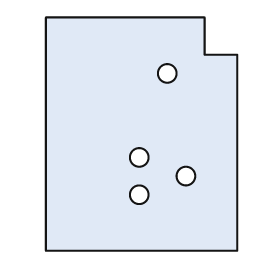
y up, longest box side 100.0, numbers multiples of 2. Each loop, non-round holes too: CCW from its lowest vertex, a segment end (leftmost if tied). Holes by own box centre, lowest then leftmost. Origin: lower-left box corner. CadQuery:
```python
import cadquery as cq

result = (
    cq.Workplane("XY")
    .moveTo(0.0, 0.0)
    .lineTo(82.0, 0.0)
    .lineTo(82.0, 84.0)
    .lineTo(68.0, 84.0)
    .lineTo(68.0, 100.0)
    .lineTo(0.0, 100.0)
    .close()
    .moveTo(40.0, 24.0)
    .circle(4.0)
    .moveTo(60.0, 32.0)
    .circle(4.0)
    .moveTo(40.0, 40.0)
    .circle(4.0)
    .moveTo(52.0, 76.0)
    .circle(4.0)
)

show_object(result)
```